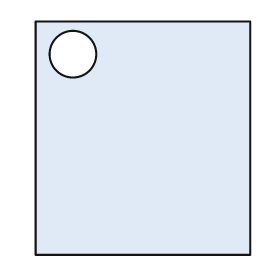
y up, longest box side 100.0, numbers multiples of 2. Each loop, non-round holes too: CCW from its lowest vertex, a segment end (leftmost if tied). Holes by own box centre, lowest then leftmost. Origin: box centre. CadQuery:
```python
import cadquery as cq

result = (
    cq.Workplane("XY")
    .moveTo(-46.0, -50.0)
    .lineTo(46.0, -50.0)
    .lineTo(46.0, 50.0)
    .lineTo(-46.0, 50.0)
    .close()
    .moveTo(-30.0, 36.0)
    .circle(10.0)
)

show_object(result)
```